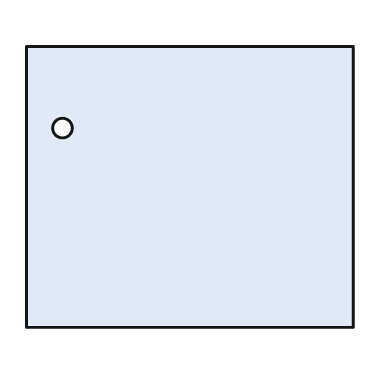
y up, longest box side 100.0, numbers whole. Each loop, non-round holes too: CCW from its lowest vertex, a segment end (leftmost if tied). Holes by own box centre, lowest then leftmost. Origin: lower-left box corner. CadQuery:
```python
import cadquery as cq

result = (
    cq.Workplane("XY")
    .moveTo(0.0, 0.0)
    .lineTo(100.0, 0.0)
    .lineTo(100.0, 86.0)
    .lineTo(0.0, 86.0)
    .close()
    .moveTo(11.0, 61.0)
    .circle(3.0)
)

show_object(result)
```